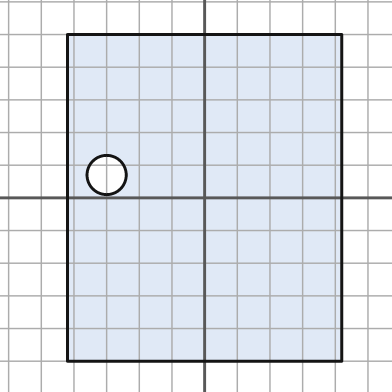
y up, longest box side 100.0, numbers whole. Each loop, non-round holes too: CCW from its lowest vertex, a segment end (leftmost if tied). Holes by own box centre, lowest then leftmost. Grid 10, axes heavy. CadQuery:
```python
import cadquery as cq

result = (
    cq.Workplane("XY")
    .moveTo(-42.0, -50.0)
    .lineTo(42.0, -50.0)
    .lineTo(42.0, 50.0)
    .lineTo(-42.0, 50.0)
    .close()
    .moveTo(-30.0, 7.0)
    .circle(6.0)
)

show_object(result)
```